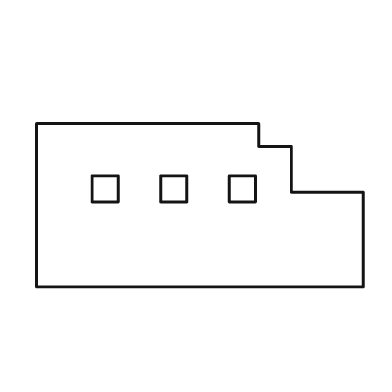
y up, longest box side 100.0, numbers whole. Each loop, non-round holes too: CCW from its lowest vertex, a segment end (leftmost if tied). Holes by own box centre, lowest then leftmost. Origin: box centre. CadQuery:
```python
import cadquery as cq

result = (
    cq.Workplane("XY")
    .moveTo(-50.0, -25.0)
    .lineTo(50.0, -25.0)
    .lineTo(50.0, 4.0)
    .lineTo(28.0, 4.0)
    .lineTo(28.0, 18.0)
    .lineTo(18.0, 18.0)
    .lineTo(18.0, 25.0)
    .lineTo(-50.0, 25.0)
    .close()
    .moveTo(-33.0, 1.0)
    .lineTo(-25.0, 1.0)
    .lineTo(-25.0, 9.0)
    .lineTo(-33.0, 9.0)
    .close()
    .moveTo(-12.0, 1.0)
    .lineTo(-4.0, 1.0)
    .lineTo(-4.0, 9.0)
    .lineTo(-12.0, 9.0)
    .close()
    .moveTo(9.0, 1.0)
    .lineTo(17.0, 1.0)
    .lineTo(17.0, 9.0)
    .lineTo(9.0, 9.0)
    .close()
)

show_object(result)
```